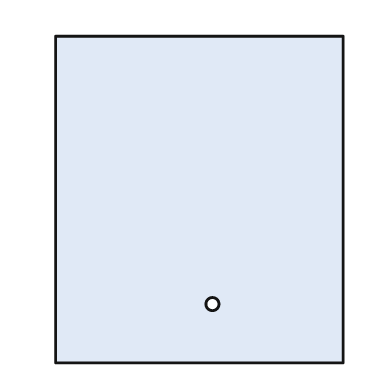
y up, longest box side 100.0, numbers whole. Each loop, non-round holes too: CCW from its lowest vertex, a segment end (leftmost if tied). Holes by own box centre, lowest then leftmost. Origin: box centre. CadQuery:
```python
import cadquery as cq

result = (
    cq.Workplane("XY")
    .moveTo(-44.0, -50.0)
    .lineTo(44.0, -50.0)
    .lineTo(44.0, 50.0)
    .lineTo(-44.0, 50.0)
    .close()
    .moveTo(4.0, -32.0)
    .circle(2.0)
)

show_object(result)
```